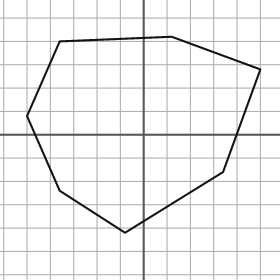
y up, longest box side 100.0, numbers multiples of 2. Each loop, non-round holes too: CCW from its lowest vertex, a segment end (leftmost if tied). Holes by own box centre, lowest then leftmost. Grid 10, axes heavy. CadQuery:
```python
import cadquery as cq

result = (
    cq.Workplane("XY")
    .moveTo(-8.0, -42.0)
    .lineTo(34.0, -16.0)
    .lineTo(50.0, 28.0)
    .lineTo(12.0, 42.0)
    .lineTo(-36.0, 40.0)
    .lineTo(-50.0, 8.0)
    .lineTo(-36.0, -24.0)
    .close()
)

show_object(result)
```